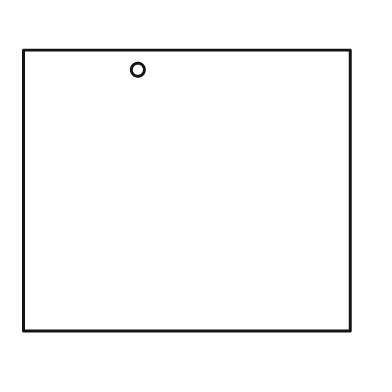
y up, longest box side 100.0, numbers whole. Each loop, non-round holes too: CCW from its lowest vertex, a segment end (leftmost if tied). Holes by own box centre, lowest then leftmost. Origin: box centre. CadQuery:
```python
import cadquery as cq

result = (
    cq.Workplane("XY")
    .moveTo(-50.0, -43.0)
    .lineTo(50.0, -43.0)
    .lineTo(50.0, 43.0)
    .lineTo(-50.0, 43.0)
    .close()
    .moveTo(-15.0, 37.0)
    .circle(2.0)
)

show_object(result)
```